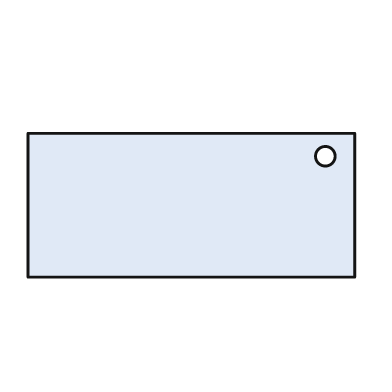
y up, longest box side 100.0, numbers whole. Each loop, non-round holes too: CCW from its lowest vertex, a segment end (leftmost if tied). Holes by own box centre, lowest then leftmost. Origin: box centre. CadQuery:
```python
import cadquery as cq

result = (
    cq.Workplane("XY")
    .moveTo(-50.0, -22.0)
    .lineTo(50.0, -22.0)
    .lineTo(50.0, 22.0)
    .lineTo(-50.0, 22.0)
    .close()
    .moveTo(41.0, 15.0)
    .circle(3.0)
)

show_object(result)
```